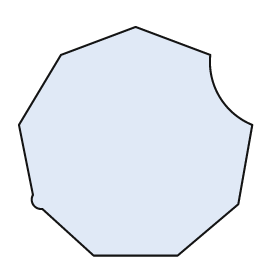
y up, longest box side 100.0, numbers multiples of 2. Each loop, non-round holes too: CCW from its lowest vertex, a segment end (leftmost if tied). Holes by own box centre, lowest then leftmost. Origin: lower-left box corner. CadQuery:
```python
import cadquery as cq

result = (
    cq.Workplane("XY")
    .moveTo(32.0, 0.0)
    .lineTo(68.0, 0.0)
    .lineTo(94.0, 22.0)
    .lineTo(100.0, 56.0)
    .threePointArc((86.0, 68.0), (82.0, 86.0))
    .lineTo(50.0, 98.0)
    .lineTo(18.0, 86.0)
    .lineTo(0.0, 56.0)
    .lineTo(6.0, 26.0)
    .threePointArc((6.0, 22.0), (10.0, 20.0))
    .close()
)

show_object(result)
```